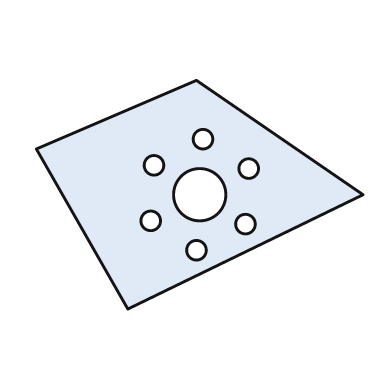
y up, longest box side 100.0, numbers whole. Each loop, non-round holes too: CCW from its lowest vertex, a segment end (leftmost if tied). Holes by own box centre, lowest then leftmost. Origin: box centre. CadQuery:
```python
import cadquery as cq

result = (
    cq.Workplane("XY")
    .moveTo(-22.0, -35.0)
    .lineTo(50.0, 0.0)
    .lineTo(-1.0, 35.0)
    .lineTo(-50.0, 14.0)
    .close()
    .moveTo(-1.0, -17.0)
    .circle(3.0)
    .moveTo(14.0, -9.0)
    .circle(3.0)
    .moveTo(-15.0, -8.0)
    .circle(3.0)
    .moveTo(0.0, 0.0)
    .circle(8.0)
    .moveTo(15.0, 8.0)
    .circle(3.0)
    .moveTo(-14.0, 9.0)
    .circle(3.0)
    .moveTo(1.0, 17.0)
    .circle(3.0)
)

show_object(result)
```